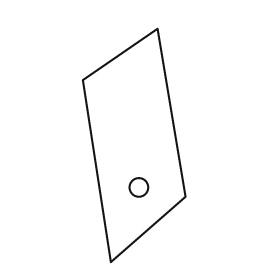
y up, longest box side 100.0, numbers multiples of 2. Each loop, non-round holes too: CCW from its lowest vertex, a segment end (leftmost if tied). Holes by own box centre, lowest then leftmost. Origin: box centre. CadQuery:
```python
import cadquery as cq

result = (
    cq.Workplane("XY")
    .moveTo(-10.0, -50.0)
    .lineTo(22.0, -22.0)
    .lineTo(10.0, 50.0)
    .lineTo(-22.0, 28.0)
    .close()
    .moveTo(2.0, -18.0)
    .circle(4.0)
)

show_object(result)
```